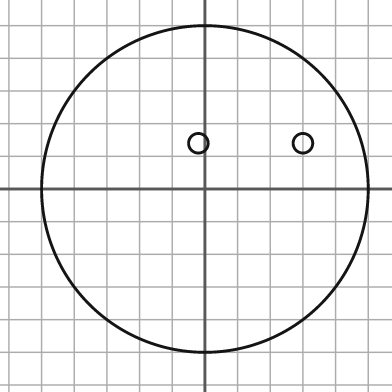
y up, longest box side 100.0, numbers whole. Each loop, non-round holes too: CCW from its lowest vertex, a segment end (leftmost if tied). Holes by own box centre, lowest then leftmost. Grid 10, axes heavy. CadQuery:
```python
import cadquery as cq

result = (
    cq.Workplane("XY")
    .moveTo(0.0, 0.0)
    .circle(50.0)
    .moveTo(-2.0, 14.0)
    .circle(3.0)
    .moveTo(30.0, 14.0)
    .circle(3.0)
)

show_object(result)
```